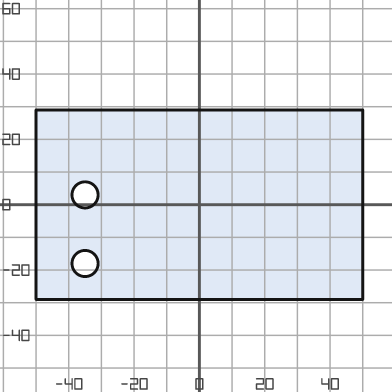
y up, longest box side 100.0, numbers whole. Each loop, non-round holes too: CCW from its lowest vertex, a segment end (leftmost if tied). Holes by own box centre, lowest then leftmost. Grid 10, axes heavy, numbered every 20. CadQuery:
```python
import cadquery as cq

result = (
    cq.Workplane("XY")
    .moveTo(-50.0, -29.0)
    .lineTo(50.0, -29.0)
    .lineTo(50.0, 29.0)
    .lineTo(-50.0, 29.0)
    .close()
    .moveTo(-35.0, -18.0)
    .circle(4.0)
    .moveTo(-35.0, 3.0)
    .circle(4.0)
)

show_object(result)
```